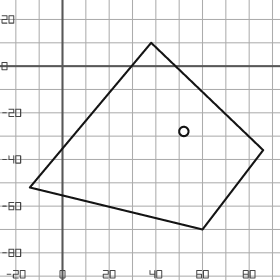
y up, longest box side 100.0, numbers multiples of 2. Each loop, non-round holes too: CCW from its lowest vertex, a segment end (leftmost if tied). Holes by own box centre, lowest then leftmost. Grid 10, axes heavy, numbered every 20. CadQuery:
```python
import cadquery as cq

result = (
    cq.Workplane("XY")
    .moveTo(60.0, -70.0)
    .lineTo(86.0, -36.0)
    .lineTo(38.0, 10.0)
    .lineTo(-14.0, -52.0)
    .close()
    .moveTo(52.0, -28.0)
    .circle(2.0)
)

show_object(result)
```